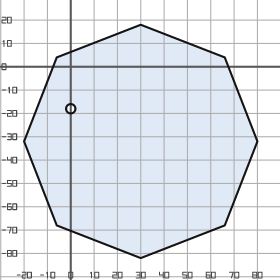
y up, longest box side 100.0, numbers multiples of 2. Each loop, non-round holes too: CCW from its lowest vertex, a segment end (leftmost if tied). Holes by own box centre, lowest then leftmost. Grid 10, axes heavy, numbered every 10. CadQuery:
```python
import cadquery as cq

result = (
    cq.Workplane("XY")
    .moveTo(30.0, -82.0)
    .lineTo(66.0, -68.0)
    .lineTo(80.0, -32.0)
    .lineTo(66.0, 4.0)
    .lineTo(30.0, 18.0)
    .lineTo(-6.0, 4.0)
    .lineTo(-20.0, -32.0)
    .lineTo(-6.0, -68.0)
    .close()
    .moveTo(0.0, -18.0)
    .circle(2.0)
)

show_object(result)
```